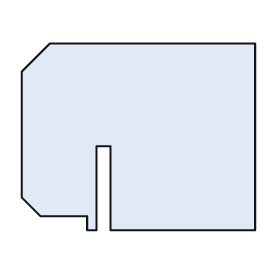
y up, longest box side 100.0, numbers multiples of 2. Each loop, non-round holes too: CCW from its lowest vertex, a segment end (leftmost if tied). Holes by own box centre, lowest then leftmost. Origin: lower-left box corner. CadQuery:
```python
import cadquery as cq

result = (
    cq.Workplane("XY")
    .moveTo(28.0, 0.0)
    .lineTo(32.0, 0.0)
    .lineTo(32.0, 36.0)
    .lineTo(38.0, 36.0)
    .lineTo(38.0, 0.0)
    .lineTo(100.0, 0.0)
    .lineTo(100.0, 80.0)
    .lineTo(12.0, 80.0)
    .lineTo(0.0, 68.0)
    .lineTo(0.0, 14.0)
    .lineTo(8.0, 6.0)
    .lineTo(28.0, 6.0)
    .close()
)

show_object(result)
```